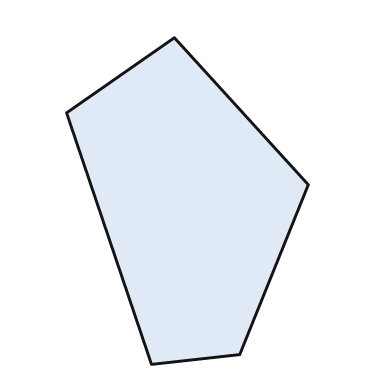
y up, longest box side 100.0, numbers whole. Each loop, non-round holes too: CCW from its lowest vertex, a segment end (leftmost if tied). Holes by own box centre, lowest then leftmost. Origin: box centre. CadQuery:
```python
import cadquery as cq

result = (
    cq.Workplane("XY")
    .moveTo(-11.0, -50.0)
    .lineTo(16.0, -47.0)
    .lineTo(37.0, 5.0)
    .lineTo(-4.0, 50.0)
    .lineTo(-37.0, 27.0)
    .close()
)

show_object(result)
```